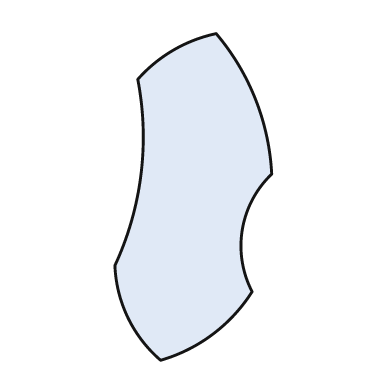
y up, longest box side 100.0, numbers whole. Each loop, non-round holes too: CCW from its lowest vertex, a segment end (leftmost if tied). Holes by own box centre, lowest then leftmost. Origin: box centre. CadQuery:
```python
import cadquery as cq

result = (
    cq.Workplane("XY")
    .moveTo(-10.0, -50.0)
    .threePointArc((6.0, -42.0), (18.0, -29.0))
    .threePointArc((15.0, -10.0), (24.0, 7.0))
    .threePointArc((19.0, 30.0), (7.0, 50.0))
    .threePointArc((-6.0, 45.0), (-17.0, 36.0))
    .threePointArc((-16.0, 7.0), (-24.0, -21.0))
    .threePointArc((-20.0, -37.0), (-10.0, -50.0))
    .close()
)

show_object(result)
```